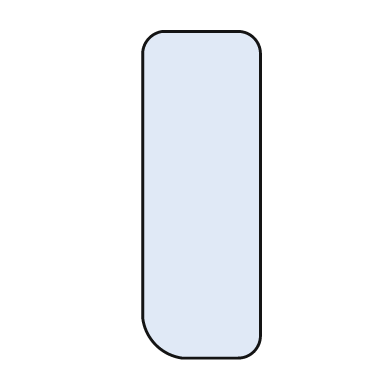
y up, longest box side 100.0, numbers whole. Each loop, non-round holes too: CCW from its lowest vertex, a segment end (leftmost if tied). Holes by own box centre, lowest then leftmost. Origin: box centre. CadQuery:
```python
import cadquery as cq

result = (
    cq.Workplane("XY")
    .moveTo(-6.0, -50.0)
    .lineTo(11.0, -50.0)
    .threePointArc((16.0, -48.0), (18.0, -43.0))
    .lineTo(18.0, 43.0)
    .threePointArc((16.0, 48.0), (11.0, 50.0))
    .lineTo(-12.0, 50.0)
    .threePointArc((-16.0, 48.0), (-18.0, 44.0))
    .lineTo(-18.0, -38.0)
    .threePointArc((-14.0, -46.0), (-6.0, -50.0))
    .close()
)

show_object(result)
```